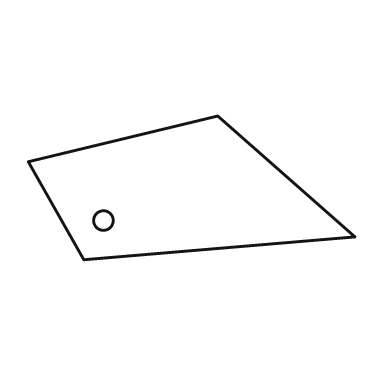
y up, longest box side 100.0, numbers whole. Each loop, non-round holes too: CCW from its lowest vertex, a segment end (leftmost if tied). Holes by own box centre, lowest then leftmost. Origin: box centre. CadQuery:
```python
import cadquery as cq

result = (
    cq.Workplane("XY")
    .moveTo(-33.0, -22.0)
    .lineTo(50.0, -15.0)
    .lineTo(8.0, 22.0)
    .lineTo(-50.0, 8.0)
    .close()
    .moveTo(-27.0, -10.0)
    .circle(3.0)
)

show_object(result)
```